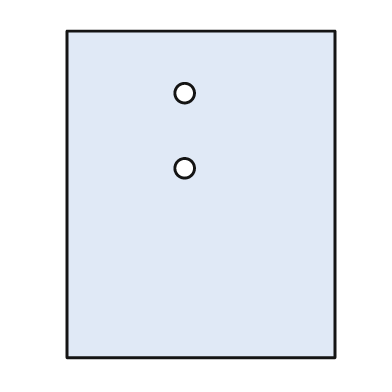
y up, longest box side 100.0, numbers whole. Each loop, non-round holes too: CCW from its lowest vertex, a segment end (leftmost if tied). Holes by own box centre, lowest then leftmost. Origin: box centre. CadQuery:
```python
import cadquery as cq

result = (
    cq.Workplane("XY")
    .moveTo(-41.0, -50.0)
    .lineTo(41.0, -50.0)
    .lineTo(41.0, 50.0)
    .lineTo(-41.0, 50.0)
    .close()
    .moveTo(-5.0, 8.0)
    .circle(3.0)
    .moveTo(-5.0, 31.0)
    .circle(3.0)
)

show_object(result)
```